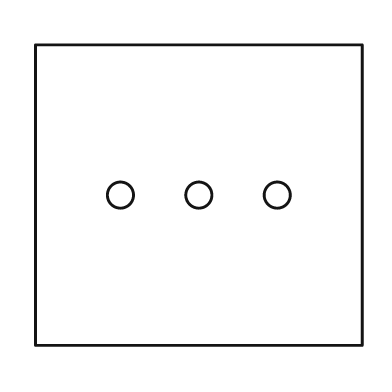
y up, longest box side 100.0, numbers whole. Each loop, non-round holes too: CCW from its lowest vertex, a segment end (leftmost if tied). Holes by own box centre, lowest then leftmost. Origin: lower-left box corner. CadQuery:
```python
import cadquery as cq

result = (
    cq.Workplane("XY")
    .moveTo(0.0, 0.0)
    .lineTo(100.0, 0.0)
    .lineTo(100.0, 92.0)
    .lineTo(0.0, 92.0)
    .close()
    .moveTo(26.0, 46.0)
    .circle(4.0)
    .moveTo(50.0, 46.0)
    .circle(4.0)
    .moveTo(74.0, 46.0)
    .circle(4.0)
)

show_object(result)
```